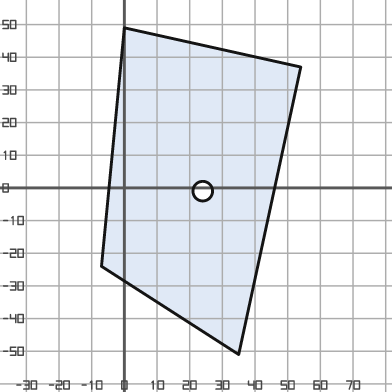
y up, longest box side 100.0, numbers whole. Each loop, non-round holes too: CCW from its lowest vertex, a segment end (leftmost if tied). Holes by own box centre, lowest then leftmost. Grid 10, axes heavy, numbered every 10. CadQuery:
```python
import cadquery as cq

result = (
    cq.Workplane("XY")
    .moveTo(35.0, -51.0)
    .lineTo(54.0, 37.0)
    .lineTo(0.0, 49.0)
    .lineTo(-7.0, -24.0)
    .close()
    .moveTo(24.0, -1.0)
    .circle(3.0)
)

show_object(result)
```